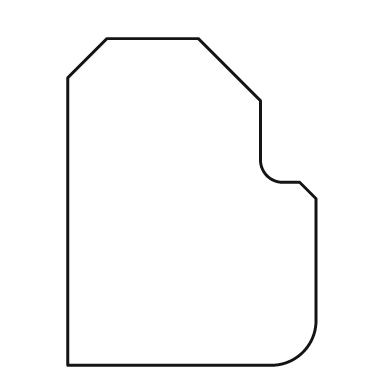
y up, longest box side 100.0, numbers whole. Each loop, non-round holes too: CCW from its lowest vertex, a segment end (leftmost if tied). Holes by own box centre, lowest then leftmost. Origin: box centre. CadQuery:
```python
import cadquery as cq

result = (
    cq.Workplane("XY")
    .moveTo(-38.0, -50.0)
    .lineTo(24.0, -50.0)
    .threePointArc((34.0, -46.0), (38.0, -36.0))
    .lineTo(38.0, 1.0)
    .lineTo(33.0, 6.0)
    .lineTo(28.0, 6.0)
    .threePointArc((23.0, 8.0), (21.0, 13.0))
    .lineTo(21.0, 31.0)
    .lineTo(2.0, 50.0)
    .lineTo(-26.0, 50.0)
    .lineTo(-38.0, 38.0)
    .close()
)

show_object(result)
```